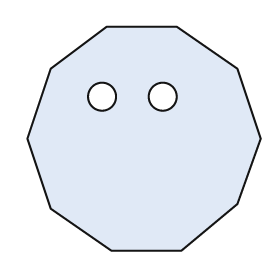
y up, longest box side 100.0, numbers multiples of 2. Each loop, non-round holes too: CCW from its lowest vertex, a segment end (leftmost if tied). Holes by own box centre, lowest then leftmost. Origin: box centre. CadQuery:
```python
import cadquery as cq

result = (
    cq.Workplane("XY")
    .moveTo(-14.0, -48.0)
    .lineTo(16.0, -48.0)
    .lineTo(40.0, -28.0)
    .lineTo(50.0, 0.0)
    .lineTo(40.0, 30.0)
    .lineTo(14.0, 48.0)
    .lineTo(-16.0, 48.0)
    .lineTo(-40.0, 30.0)
    .lineTo(-50.0, 0.0)
    .lineTo(-40.0, -30.0)
    .close()
    .moveTo(-18.0, 18.0)
    .circle(6.0)
    .moveTo(8.0, 18.0)
    .circle(6.0)
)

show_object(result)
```